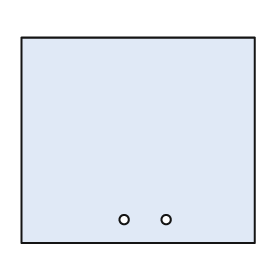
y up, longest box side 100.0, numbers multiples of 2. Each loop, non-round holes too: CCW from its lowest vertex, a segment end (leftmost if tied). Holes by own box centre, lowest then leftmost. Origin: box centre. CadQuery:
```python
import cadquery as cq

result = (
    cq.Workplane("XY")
    .moveTo(-50.0, -44.0)
    .lineTo(50.0, -44.0)
    .lineTo(50.0, 44.0)
    .lineTo(-50.0, 44.0)
    .close()
    .moveTo(-6.0, -34.0)
    .circle(2.0)
    .moveTo(12.0, -34.0)
    .circle(2.0)
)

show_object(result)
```